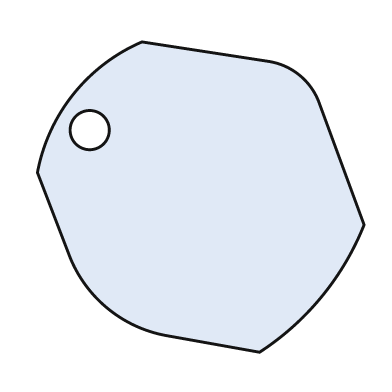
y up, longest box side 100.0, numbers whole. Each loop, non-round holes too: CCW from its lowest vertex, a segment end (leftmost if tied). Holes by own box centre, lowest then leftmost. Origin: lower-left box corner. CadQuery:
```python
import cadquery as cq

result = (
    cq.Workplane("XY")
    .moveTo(68.0, 0.0)
    .threePointArc((87.0, 17.0), (100.0, 39.0))
    .lineTo(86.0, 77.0)
    .threePointArc((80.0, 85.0), (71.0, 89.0))
    .lineTo(32.0, 95.0)
    .threePointArc((11.0, 79.0), (0.0, 55.0))
    .lineTo(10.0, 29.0)
    .threePointArc((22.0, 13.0), (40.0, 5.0))
    .close()
    .moveTo(16.0, 68.0)
    .circle(6.0)
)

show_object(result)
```